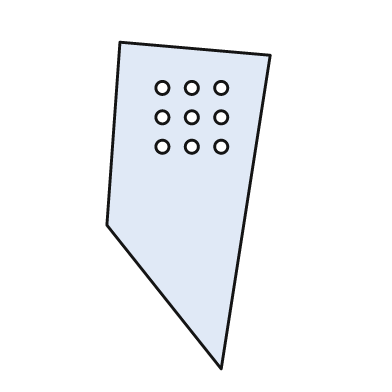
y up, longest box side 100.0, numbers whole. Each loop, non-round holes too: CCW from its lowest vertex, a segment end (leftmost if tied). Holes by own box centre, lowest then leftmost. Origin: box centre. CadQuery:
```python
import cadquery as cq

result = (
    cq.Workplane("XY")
    .moveTo(10.0, -50.0)
    .lineTo(25.0, 46.0)
    .lineTo(-21.0, 50.0)
    .lineTo(-25.0, -6.0)
    .close()
    .moveTo(-8.0, 18.0)
    .circle(2.0)
    .moveTo(1.0, 18.0)
    .circle(2.0)
    .moveTo(10.0, 18.0)
    .circle(2.0)
    .moveTo(-8.0, 27.0)
    .circle(2.0)
    .moveTo(1.0, 27.0)
    .circle(2.0)
    .moveTo(10.0, 27.0)
    .circle(2.0)
    .moveTo(-8.0, 36.0)
    .circle(2.0)
    .moveTo(1.0, 36.0)
    .circle(2.0)
    .moveTo(10.0, 36.0)
    .circle(2.0)
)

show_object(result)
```